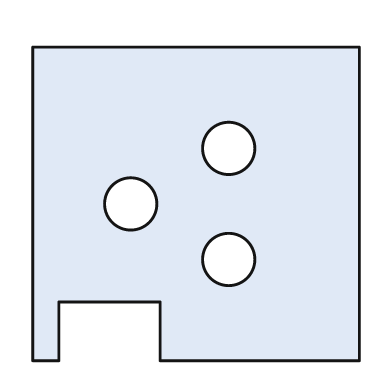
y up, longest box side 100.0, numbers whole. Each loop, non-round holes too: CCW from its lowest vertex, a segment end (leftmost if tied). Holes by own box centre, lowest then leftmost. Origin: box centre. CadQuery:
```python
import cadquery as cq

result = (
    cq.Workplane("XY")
    .moveTo(-50.0, -48.0)
    .lineTo(-42.0, -48.0)
    .lineTo(-42.0, -30.0)
    .lineTo(-11.0, -30.0)
    .lineTo(-11.0, -48.0)
    .lineTo(50.0, -48.0)
    .lineTo(50.0, 48.0)
    .lineTo(-50.0, 48.0)
    .close()
    .moveTo(10.0, -17.0)
    .circle(8.0)
    .moveTo(-20.0, 0.0)
    .circle(8.0)
    .moveTo(10.0, 17.0)
    .circle(8.0)
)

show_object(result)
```